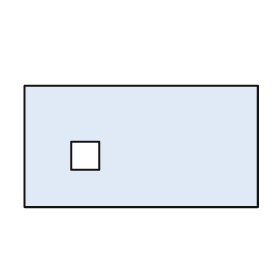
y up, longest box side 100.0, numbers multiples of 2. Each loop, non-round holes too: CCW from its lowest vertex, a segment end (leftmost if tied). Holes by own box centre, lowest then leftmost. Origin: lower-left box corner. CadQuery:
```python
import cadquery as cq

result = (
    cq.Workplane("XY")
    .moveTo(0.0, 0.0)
    .lineTo(100.0, 0.0)
    .lineTo(100.0, 52.0)
    .lineTo(0.0, 52.0)
    .close()
    .moveTo(20.0, 16.0)
    .lineTo(32.0, 16.0)
    .lineTo(32.0, 28.0)
    .lineTo(20.0, 28.0)
    .close()
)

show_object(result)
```